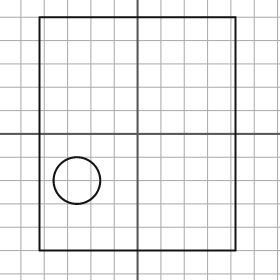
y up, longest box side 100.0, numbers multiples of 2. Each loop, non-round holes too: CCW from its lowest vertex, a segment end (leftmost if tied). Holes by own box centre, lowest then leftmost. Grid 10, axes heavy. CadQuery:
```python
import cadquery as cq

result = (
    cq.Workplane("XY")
    .moveTo(-42.0, -50.0)
    .lineTo(42.0, -50.0)
    .lineTo(42.0, 50.0)
    .lineTo(-42.0, 50.0)
    .close()
    .moveTo(-26.0, -20.0)
    .circle(10.0)
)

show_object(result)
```